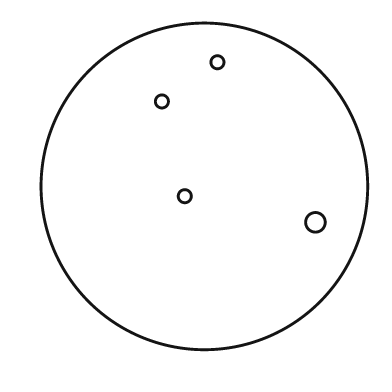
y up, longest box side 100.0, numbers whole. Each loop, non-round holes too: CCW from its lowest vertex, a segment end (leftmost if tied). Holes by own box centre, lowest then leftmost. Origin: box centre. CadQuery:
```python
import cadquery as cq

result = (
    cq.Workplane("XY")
    .moveTo(0.0, 0.0)
    .circle(50.0)
    .moveTo(34.0, -11.0)
    .circle(3.0)
    .moveTo(-6.0, -3.0)
    .circle(2.0)
    .moveTo(-13.0, 26.0)
    .circle(2.0)
    .moveTo(4.0, 38.0)
    .circle(2.0)
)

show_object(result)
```